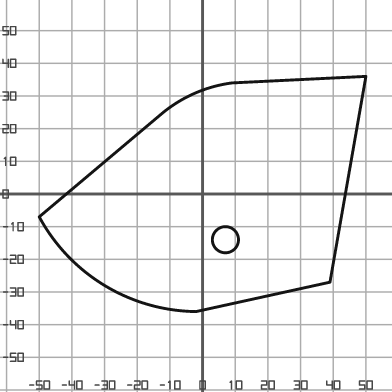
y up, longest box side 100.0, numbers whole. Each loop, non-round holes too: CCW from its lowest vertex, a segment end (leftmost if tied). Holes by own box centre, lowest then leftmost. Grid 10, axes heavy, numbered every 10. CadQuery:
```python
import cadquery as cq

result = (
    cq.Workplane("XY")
    .moveTo(-2.0, -36.0)
    .lineTo(39.0, -27.0)
    .lineTo(50.0, 36.0)
    .lineTo(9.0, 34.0)
    .threePointArc((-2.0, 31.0), (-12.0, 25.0))
    .lineTo(-50.0, -7.0)
    .threePointArc((-30.0, -28.0), (-2.0, -36.0))
    .close()
    .moveTo(7.0, -14.0)
    .circle(4.0)
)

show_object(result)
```